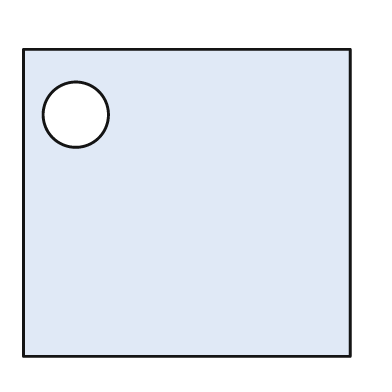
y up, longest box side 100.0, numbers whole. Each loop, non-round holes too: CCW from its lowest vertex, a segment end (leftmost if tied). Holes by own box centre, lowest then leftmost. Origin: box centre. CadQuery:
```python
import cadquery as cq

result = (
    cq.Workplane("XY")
    .moveTo(-50.0, -47.0)
    .lineTo(50.0, -47.0)
    .lineTo(50.0, 47.0)
    .lineTo(-50.0, 47.0)
    .close()
    .moveTo(-34.0, 27.0)
    .circle(10.0)
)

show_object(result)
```